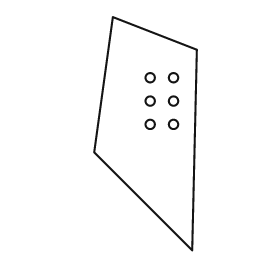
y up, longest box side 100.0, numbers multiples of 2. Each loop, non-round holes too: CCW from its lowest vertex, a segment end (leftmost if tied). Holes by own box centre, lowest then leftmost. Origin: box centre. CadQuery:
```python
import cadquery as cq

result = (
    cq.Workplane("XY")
    .moveTo(20.0, -50.0)
    .lineTo(22.0, 36.0)
    .lineTo(-14.0, 50.0)
    .lineTo(-22.0, -8.0)
    .close()
    .moveTo(2.0, 4.0)
    .circle(2.0)
    .moveTo(12.0, 4.0)
    .circle(2.0)
    .moveTo(2.0, 14.0)
    .circle(2.0)
    .moveTo(12.0, 14.0)
    .circle(2.0)
    .moveTo(2.0, 24.0)
    .circle(2.0)
    .moveTo(12.0, 24.0)
    .circle(2.0)
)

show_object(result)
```